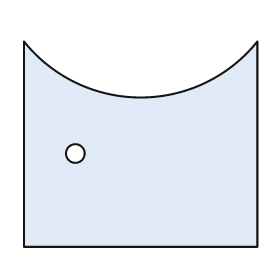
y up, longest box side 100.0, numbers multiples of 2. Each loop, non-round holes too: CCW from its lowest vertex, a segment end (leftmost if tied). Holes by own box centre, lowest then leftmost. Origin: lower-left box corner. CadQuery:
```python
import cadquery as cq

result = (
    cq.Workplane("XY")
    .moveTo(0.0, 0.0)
    .lineTo(100.0, 0.0)
    .lineTo(100.0, 88.0)
    .threePointArc((50.0, 64.0), (0.0, 88.0))
    .close()
    .moveTo(22.0, 40.0)
    .circle(4.0)
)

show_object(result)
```